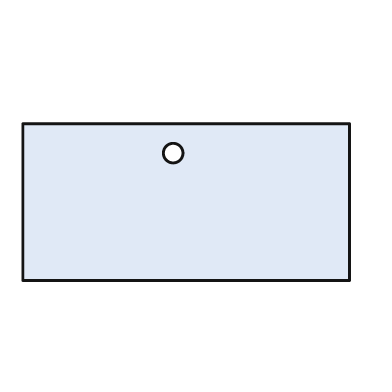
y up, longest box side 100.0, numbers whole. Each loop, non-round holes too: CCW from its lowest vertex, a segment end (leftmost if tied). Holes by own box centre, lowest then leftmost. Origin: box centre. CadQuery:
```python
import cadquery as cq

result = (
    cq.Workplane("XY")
    .moveTo(-50.0, -24.0)
    .lineTo(50.0, -24.0)
    .lineTo(50.0, 24.0)
    .lineTo(-50.0, 24.0)
    .close()
    .moveTo(-4.0, 15.0)
    .circle(3.0)
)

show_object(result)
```